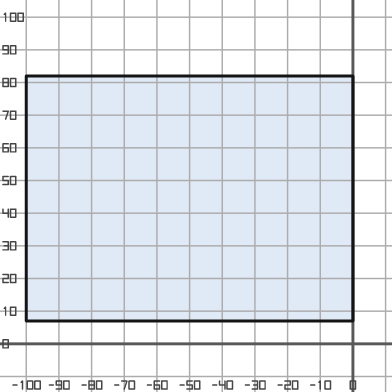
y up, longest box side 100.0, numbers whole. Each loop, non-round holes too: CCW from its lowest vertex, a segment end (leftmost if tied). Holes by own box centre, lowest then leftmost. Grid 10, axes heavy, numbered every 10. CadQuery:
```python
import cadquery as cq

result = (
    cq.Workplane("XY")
    .moveTo(-100.0, 7.0)
    .lineTo(0.0, 7.0)
    .lineTo(0.0, 82.0)
    .lineTo(-100.0, 82.0)
    .close()
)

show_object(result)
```